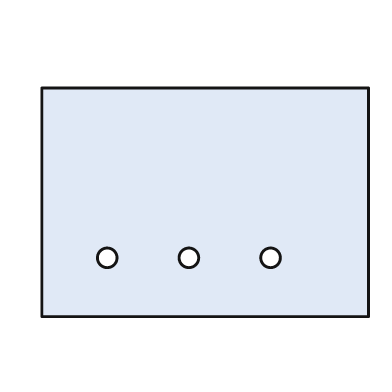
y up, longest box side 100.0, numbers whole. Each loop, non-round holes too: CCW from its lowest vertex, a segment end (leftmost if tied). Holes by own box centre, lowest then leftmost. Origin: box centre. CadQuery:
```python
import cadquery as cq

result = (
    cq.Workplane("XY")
    .moveTo(-50.0, -35.0)
    .lineTo(50.0, -35.0)
    .lineTo(50.0, 35.0)
    .lineTo(-50.0, 35.0)
    .close()
    .moveTo(-30.0, -17.0)
    .circle(3.0)
    .moveTo(-5.0, -17.0)
    .circle(3.0)
    .moveTo(20.0, -17.0)
    .circle(3.0)
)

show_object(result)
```